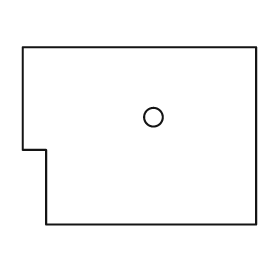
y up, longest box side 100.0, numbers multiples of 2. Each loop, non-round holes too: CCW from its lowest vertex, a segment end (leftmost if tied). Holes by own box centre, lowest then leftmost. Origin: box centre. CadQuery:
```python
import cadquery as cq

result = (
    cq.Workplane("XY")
    .moveTo(-40.0, -38.0)
    .lineTo(50.0, -38.0)
    .lineTo(50.0, 38.0)
    .lineTo(-50.0, 38.0)
    .lineTo(-50.0, -6.0)
    .lineTo(-40.0, -6.0)
    .close()
    .moveTo(6.0, 8.0)
    .circle(4.0)
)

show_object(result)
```